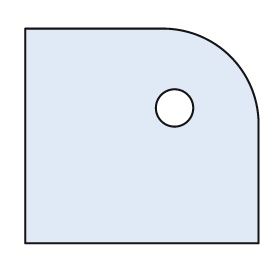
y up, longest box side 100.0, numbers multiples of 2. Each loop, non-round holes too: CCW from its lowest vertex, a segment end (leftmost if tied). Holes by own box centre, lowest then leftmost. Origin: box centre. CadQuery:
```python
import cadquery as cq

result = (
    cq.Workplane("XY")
    .moveTo(-50.0, -46.0)
    .lineTo(50.0, -46.0)
    .lineTo(50.0, 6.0)
    .threePointArc((38.0, 34.0), (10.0, 46.0))
    .lineTo(-50.0, 46.0)
    .close()
    .moveTo(14.0, 12.0)
    .circle(8.0)
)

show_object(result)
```